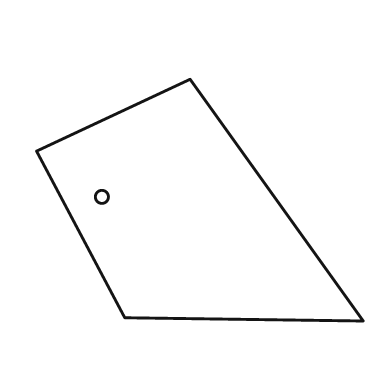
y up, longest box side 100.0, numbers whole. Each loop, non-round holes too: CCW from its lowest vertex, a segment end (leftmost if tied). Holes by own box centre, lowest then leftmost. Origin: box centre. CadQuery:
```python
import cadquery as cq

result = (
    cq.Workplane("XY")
    .moveTo(50.0, -37.0)
    .lineTo(-3.0, 37.0)
    .lineTo(-50.0, 15.0)
    .lineTo(-23.0, -36.0)
    .close()
    .moveTo(-30.0, 1.0)
    .circle(2.0)
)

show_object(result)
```